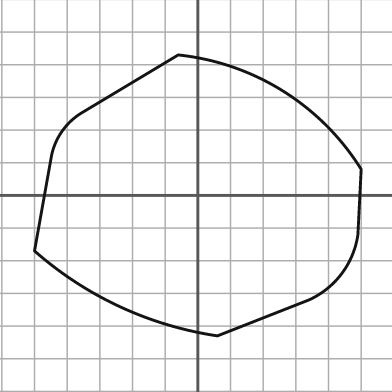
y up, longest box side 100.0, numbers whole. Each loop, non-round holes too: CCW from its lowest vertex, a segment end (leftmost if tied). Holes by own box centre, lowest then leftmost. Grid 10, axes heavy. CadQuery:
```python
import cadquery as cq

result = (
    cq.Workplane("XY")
    .moveTo(6.0, -43.0)
    .lineTo(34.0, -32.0)
    .threePointArc((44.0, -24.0), (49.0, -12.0))
    .lineTo(50.0, 8.0)
    .threePointArc((26.0, 32.0), (-6.0, 43.0))
    .lineTo(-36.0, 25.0)
    .threePointArc((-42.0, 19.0), (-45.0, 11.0))
    .lineTo(-50.0, -17.0)
    .threePointArc((-24.0, -34.0), (6.0, -43.0))
    .close()
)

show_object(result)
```